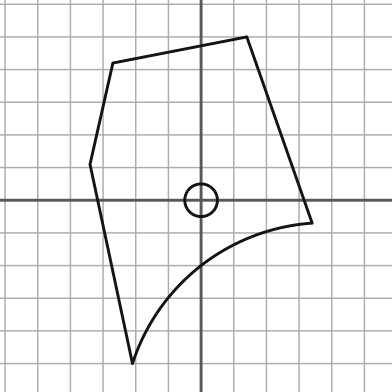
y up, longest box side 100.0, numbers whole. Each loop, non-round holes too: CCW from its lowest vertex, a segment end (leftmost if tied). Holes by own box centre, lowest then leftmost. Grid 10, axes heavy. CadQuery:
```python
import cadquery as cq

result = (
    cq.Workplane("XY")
    .moveTo(-21.0, -50.0)
    .threePointArc((0.0, -20.0), (34.0, -7.0))
    .lineTo(14.0, 50.0)
    .lineTo(-27.0, 42.0)
    .lineTo(-34.0, 11.0)
    .close()
    .moveTo(0.0, 0.0)
    .circle(5.0)
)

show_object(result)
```